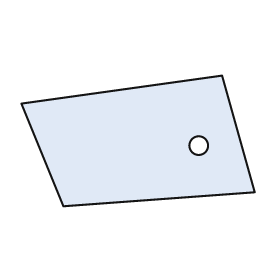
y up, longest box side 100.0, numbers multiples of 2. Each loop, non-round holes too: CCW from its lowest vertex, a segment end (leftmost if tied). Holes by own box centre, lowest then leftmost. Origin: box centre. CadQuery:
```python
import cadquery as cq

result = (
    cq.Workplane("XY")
    .moveTo(-32.0, -28.0)
    .lineTo(50.0, -22.0)
    .lineTo(36.0, 28.0)
    .lineTo(-50.0, 16.0)
    .close()
    .moveTo(26.0, -2.0)
    .circle(4.0)
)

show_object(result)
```